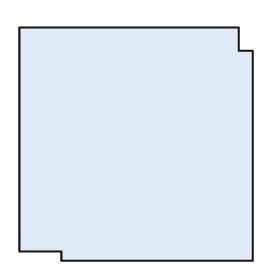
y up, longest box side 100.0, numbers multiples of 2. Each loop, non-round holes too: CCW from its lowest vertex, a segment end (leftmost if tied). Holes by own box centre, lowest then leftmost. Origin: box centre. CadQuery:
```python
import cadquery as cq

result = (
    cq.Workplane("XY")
    .moveTo(-32.0, -50.0)
    .lineTo(50.0, -50.0)
    .lineTo(50.0, 40.0)
    .lineTo(44.0, 40.0)
    .lineTo(44.0, 50.0)
    .lineTo(-50.0, 50.0)
    .lineTo(-50.0, -46.0)
    .lineTo(-32.0, -46.0)
    .close()
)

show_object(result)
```